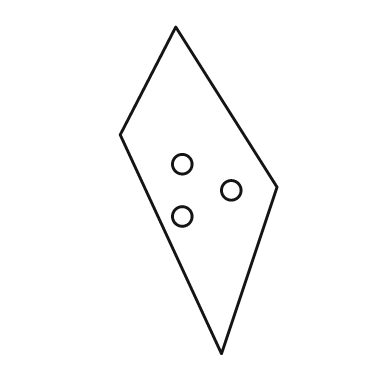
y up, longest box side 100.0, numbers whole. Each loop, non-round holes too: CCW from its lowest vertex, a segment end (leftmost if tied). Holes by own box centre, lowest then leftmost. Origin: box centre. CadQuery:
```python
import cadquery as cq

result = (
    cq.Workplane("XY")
    .moveTo(7.0, -50.0)
    .lineTo(24.0, 1.0)
    .lineTo(-7.0, 50.0)
    .lineTo(-24.0, 17.0)
    .close()
    .moveTo(-5.0, -8.0)
    .circle(3.0)
    .moveTo(10.0, 0.0)
    .circle(3.0)
    .moveTo(-5.0, 8.0)
    .circle(3.0)
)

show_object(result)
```